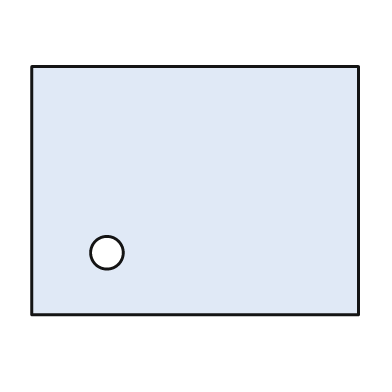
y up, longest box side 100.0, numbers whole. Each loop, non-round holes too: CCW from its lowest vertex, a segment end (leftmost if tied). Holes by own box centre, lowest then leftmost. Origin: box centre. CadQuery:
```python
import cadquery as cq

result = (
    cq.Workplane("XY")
    .moveTo(-50.0, -38.0)
    .lineTo(50.0, -38.0)
    .lineTo(50.0, 38.0)
    .lineTo(-50.0, 38.0)
    .close()
    .moveTo(-27.0, -19.0)
    .circle(5.0)
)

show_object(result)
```